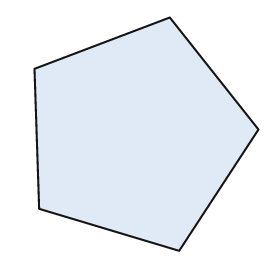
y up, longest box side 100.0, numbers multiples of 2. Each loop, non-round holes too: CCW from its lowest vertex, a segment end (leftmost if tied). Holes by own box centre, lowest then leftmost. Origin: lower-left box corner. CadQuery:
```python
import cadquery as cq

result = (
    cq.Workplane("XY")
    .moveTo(62.0, 0.0)
    .lineTo(96.0, 52.0)
    .lineTo(58.0, 100.0)
    .lineTo(0.0, 78.0)
    .lineTo(2.0, 18.0)
    .close()
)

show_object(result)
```